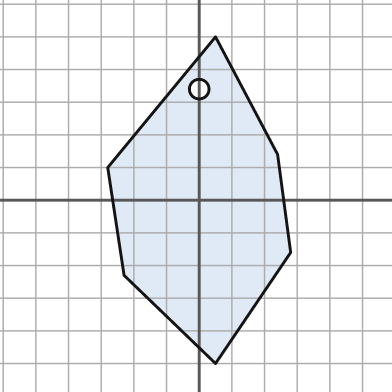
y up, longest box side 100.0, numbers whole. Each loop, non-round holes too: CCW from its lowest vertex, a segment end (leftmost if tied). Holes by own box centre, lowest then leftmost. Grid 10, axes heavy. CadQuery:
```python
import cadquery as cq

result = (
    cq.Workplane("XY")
    .moveTo(5.0, -50.0)
    .lineTo(28.0, -16.0)
    .lineTo(24.0, 14.0)
    .lineTo(5.0, 50.0)
    .lineTo(-28.0, 10.0)
    .lineTo(-23.0, -23.0)
    .close()
    .moveTo(0.0, 34.0)
    .circle(3.0)
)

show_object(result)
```